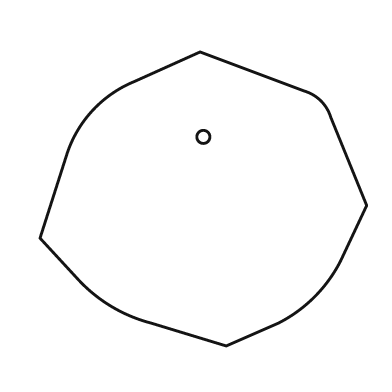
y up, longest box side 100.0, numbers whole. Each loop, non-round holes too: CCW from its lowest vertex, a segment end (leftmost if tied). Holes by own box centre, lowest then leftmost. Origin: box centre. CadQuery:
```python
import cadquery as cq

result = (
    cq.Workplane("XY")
    .moveTo(7.0, -45.0)
    .lineTo(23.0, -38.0)
    .threePointArc((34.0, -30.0), (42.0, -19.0))
    .lineTo(50.0, -2.0)
    .lineTo(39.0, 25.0)
    .threePointArc((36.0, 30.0), (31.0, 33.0))
    .lineTo(-1.0, 45.0)
    .lineTo(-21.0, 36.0)
    .threePointArc((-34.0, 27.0), (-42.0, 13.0))
    .lineTo(-50.0, -12.0)
    .lineTo(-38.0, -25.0)
    .threePointArc((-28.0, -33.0), (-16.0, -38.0))
    .close()
    .moveTo(0.0, 19.0)
    .circle(2.0)
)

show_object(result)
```